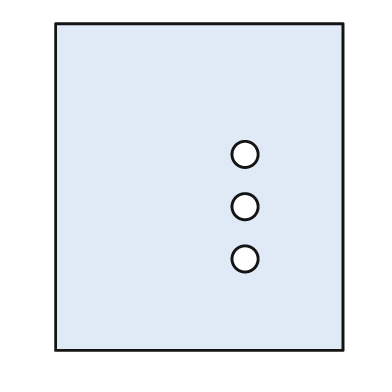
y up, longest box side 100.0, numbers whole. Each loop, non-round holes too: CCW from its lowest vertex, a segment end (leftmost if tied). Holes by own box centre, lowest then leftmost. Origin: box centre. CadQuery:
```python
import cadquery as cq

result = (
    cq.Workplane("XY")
    .moveTo(-44.0, -50.0)
    .lineTo(44.0, -50.0)
    .lineTo(44.0, 50.0)
    .lineTo(-44.0, 50.0)
    .close()
    .moveTo(14.0, -22.0)
    .circle(4.0)
    .moveTo(14.0, -6.0)
    .circle(4.0)
    .moveTo(14.0, 10.0)
    .circle(4.0)
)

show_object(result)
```